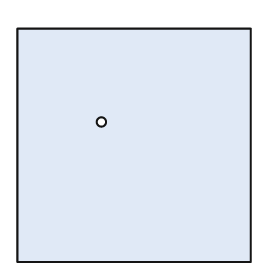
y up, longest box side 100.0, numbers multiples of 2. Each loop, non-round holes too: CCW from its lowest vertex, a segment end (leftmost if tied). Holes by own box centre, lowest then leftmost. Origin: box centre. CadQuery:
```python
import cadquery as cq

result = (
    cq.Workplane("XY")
    .moveTo(-50.0, -50.0)
    .lineTo(50.0, -50.0)
    .lineTo(50.0, 50.0)
    .lineTo(-50.0, 50.0)
    .close()
    .moveTo(-14.0, 10.0)
    .circle(2.0)
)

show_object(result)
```